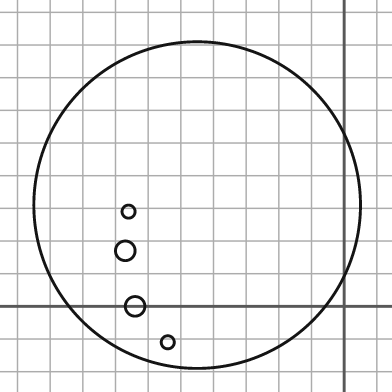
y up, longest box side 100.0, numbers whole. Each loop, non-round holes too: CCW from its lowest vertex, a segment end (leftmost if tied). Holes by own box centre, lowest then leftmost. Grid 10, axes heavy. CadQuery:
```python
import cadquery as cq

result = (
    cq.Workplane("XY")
    .moveTo(-45.0, 31.0)
    .circle(50.0)
    .moveTo(-54.0, -11.0)
    .circle(2.0)
    .moveTo(-64.0, 0.0)
    .circle(3.0)
    .moveTo(-67.0, 17.0)
    .circle(3.0)
    .moveTo(-66.0, 29.0)
    .circle(2.0)
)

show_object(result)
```